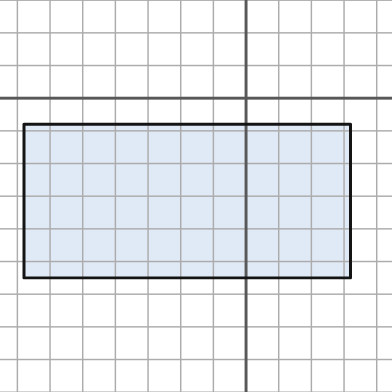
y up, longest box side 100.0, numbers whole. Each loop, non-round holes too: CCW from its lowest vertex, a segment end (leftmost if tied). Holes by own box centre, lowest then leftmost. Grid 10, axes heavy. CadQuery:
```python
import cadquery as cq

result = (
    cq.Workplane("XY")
    .moveTo(-68.0, -55.0)
    .lineTo(32.0, -55.0)
    .lineTo(32.0, -8.0)
    .lineTo(-68.0, -8.0)
    .close()
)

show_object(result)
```